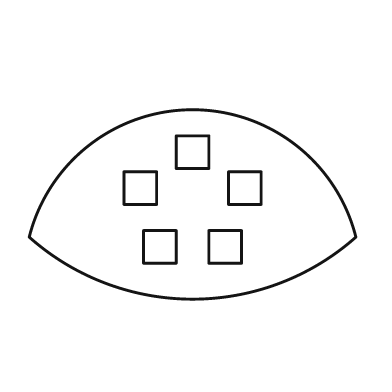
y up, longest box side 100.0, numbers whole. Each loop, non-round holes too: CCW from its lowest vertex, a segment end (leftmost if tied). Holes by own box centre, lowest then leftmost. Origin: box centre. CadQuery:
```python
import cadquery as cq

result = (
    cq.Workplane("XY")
    .moveTo(-50.0, -10.0)
    .threePointArc((0.0, -29.0), (50.0, -10.0))
    .threePointArc((0.0, 29.0), (-50.0, -10.0))
    .close()
    .moveTo(-15.0, -18.0)
    .lineTo(-5.0, -18.0)
    .lineTo(-5.0, -8.0)
    .lineTo(-15.0, -8.0)
    .close()
    .moveTo(5.0, -18.0)
    .lineTo(15.0, -18.0)
    .lineTo(15.0, -8.0)
    .lineTo(5.0, -8.0)
    .close()
    .moveTo(-21.0, 0.0)
    .lineTo(-11.0, 0.0)
    .lineTo(-11.0, 10.0)
    .lineTo(-21.0, 10.0)
    .close()
    .moveTo(11.0, 0.0)
    .lineTo(21.0, 0.0)
    .lineTo(21.0, 10.0)
    .lineTo(11.0, 10.0)
    .close()
    .moveTo(-5.0, 11.0)
    .lineTo(5.0, 11.0)
    .lineTo(5.0, 21.0)
    .lineTo(-5.0, 21.0)
    .close()
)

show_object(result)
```